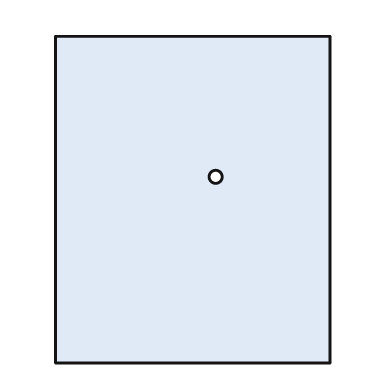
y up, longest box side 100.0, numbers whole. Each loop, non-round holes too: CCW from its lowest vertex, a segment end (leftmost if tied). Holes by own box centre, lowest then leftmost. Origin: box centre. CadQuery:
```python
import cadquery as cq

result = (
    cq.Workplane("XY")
    .moveTo(-42.0, -50.0)
    .lineTo(42.0, -50.0)
    .lineTo(42.0, 50.0)
    .lineTo(-42.0, 50.0)
    .close()
    .moveTo(7.0, 7.0)
    .circle(2.0)
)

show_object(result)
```